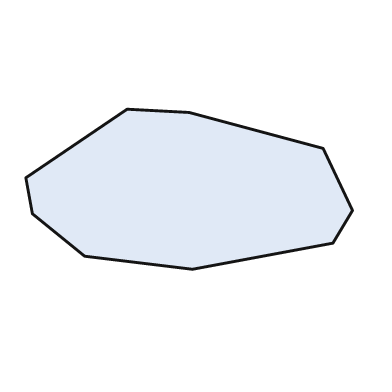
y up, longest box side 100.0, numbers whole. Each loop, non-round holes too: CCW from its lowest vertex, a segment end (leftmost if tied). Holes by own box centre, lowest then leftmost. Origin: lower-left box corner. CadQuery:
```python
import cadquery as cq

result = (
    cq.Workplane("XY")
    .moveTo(51.0, 0.0)
    .lineTo(94.0, 8.0)
    .lineTo(100.0, 18.0)
    .lineTo(91.0, 37.0)
    .lineTo(50.0, 48.0)
    .lineTo(31.0, 49.0)
    .lineTo(0.0, 28.0)
    .lineTo(2.0, 17.0)
    .lineTo(18.0, 4.0)
    .close()
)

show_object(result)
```